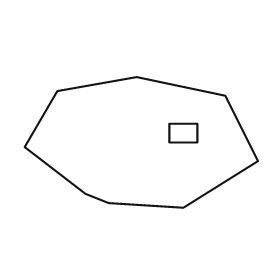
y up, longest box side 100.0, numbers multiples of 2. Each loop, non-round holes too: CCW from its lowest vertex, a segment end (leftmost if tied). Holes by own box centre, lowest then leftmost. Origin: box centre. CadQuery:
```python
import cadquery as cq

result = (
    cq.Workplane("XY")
    .moveTo(18.0, -28.0)
    .lineTo(50.0, -8.0)
    .lineTo(36.0, 20.0)
    .lineTo(-2.0, 28.0)
    .lineTo(-36.0, 22.0)
    .lineTo(-50.0, -2.0)
    .lineTo(-24.0, -22.0)
    .lineTo(-14.0, -26.0)
    .close()
    .moveTo(12.0, 0.0)
    .lineTo(24.0, 0.0)
    .lineTo(24.0, 8.0)
    .lineTo(12.0, 8.0)
    .close()
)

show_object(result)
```